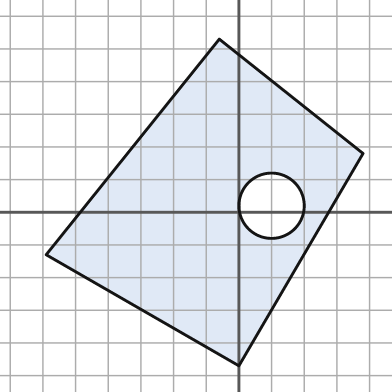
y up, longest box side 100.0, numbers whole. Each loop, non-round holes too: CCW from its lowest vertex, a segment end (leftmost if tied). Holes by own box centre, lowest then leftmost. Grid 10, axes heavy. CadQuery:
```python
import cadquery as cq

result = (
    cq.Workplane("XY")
    .moveTo(0.0, -47.0)
    .lineTo(38.0, 18.0)
    .lineTo(-6.0, 53.0)
    .lineTo(-59.0, -13.0)
    .close()
    .moveTo(10.0, 2.0)
    .circle(10.0)
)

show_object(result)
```